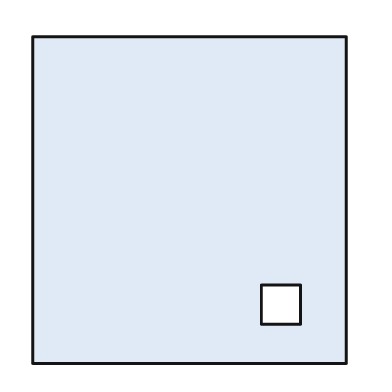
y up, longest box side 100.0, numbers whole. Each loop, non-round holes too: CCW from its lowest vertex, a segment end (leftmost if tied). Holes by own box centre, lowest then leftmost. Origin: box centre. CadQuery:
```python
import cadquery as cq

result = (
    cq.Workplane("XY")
    .moveTo(-48.0, -50.0)
    .lineTo(48.0, -50.0)
    .lineTo(48.0, 50.0)
    .lineTo(-48.0, 50.0)
    .close()
    .moveTo(22.0, -38.0)
    .lineTo(34.0, -38.0)
    .lineTo(34.0, -26.0)
    .lineTo(22.0, -26.0)
    .close()
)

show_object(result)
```